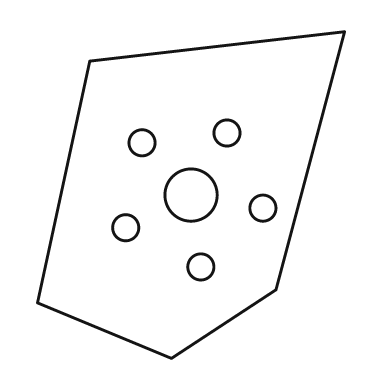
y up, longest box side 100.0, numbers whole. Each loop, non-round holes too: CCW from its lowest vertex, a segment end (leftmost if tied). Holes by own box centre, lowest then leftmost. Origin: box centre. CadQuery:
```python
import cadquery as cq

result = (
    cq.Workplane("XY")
    .moveTo(-6.0, -50.0)
    .lineTo(26.0, -29.0)
    .lineTo(47.0, 50.0)
    .lineTo(-31.0, 41.0)
    .lineTo(-47.0, -33.0)
    .close()
    .moveTo(3.0, -22.0)
    .circle(4.0)
    .moveTo(-20.0, -10.0)
    .circle(4.0)
    .moveTo(22.0, -4.0)
    .circle(4.0)
    .moveTo(0.0, 0.0)
    .circle(8.0)
    .moveTo(-15.0, 16.0)
    .circle(4.0)
    .moveTo(11.0, 19.0)
    .circle(4.0)
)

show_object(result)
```